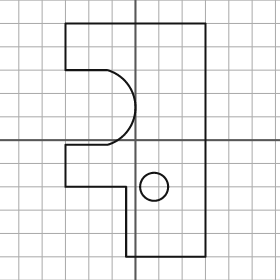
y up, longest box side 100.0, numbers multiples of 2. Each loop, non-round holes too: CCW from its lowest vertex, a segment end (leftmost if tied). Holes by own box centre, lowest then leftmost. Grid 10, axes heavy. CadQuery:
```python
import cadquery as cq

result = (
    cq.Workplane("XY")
    .moveTo(-4.0, -50.0)
    .lineTo(30.0, -50.0)
    .lineTo(30.0, 50.0)
    .lineTo(-30.0, 50.0)
    .lineTo(-30.0, 30.0)
    .lineTo(-12.0, 30.0)
    .threePointArc((0.0, 14.0), (-12.0, -2.0))
    .lineTo(-30.0, -2.0)
    .lineTo(-30.0, -20.0)
    .lineTo(-4.0, -20.0)
    .close()
    .moveTo(8.0, -20.0)
    .circle(6.0)
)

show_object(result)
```